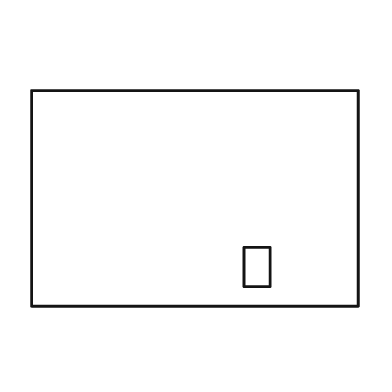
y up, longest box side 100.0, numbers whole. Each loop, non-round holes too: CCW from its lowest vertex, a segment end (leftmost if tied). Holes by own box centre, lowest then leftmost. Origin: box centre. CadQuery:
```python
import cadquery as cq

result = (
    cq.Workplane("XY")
    .moveTo(-50.0, -33.0)
    .lineTo(50.0, -33.0)
    .lineTo(50.0, 33.0)
    .lineTo(-50.0, 33.0)
    .close()
    .moveTo(15.0, -27.0)
    .lineTo(23.0, -27.0)
    .lineTo(23.0, -15.0)
    .lineTo(15.0, -15.0)
    .close()
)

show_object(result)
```